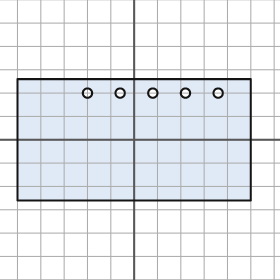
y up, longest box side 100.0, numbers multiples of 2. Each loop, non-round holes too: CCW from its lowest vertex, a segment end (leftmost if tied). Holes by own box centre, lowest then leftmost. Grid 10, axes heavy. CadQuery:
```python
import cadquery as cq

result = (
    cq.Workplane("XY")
    .moveTo(-50.0, -26.0)
    .lineTo(50.0, -26.0)
    .lineTo(50.0, 26.0)
    .lineTo(-50.0, 26.0)
    .close()
    .moveTo(-20.0, 20.0)
    .circle(2.0)
    .moveTo(-6.0, 20.0)
    .circle(2.0)
    .moveTo(8.0, 20.0)
    .circle(2.0)
    .moveTo(22.0, 20.0)
    .circle(2.0)
    .moveTo(36.0, 20.0)
    .circle(2.0)
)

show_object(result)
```